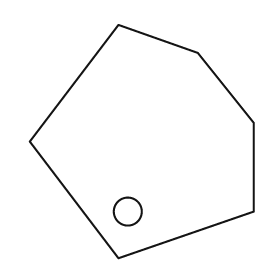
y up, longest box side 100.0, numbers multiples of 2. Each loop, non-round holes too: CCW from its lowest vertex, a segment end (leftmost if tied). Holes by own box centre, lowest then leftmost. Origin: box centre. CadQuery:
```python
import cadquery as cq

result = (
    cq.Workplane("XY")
    .moveTo(-10.0, -50.0)
    .lineTo(48.0, -30.0)
    .lineTo(48.0, 8.0)
    .lineTo(24.0, 38.0)
    .lineTo(-10.0, 50.0)
    .lineTo(-48.0, 0.0)
    .close()
    .moveTo(-6.0, -30.0)
    .circle(6.0)
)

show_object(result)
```